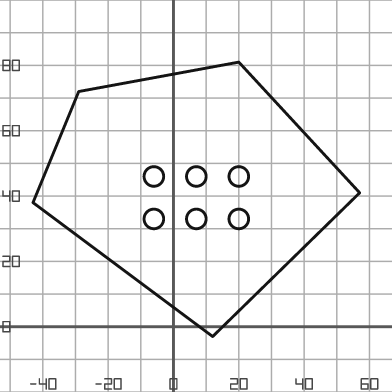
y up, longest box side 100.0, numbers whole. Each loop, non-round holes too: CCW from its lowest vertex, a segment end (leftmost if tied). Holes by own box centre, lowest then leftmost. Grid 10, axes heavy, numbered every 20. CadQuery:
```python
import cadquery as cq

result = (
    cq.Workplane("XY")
    .moveTo(12.0, -3.0)
    .lineTo(57.0, 41.0)
    .lineTo(20.0, 81.0)
    .lineTo(-29.0, 72.0)
    .lineTo(-43.0, 38.0)
    .close()
    .moveTo(-6.0, 33.0)
    .circle(3.0)
    .moveTo(7.0, 33.0)
    .circle(3.0)
    .moveTo(20.0, 33.0)
    .circle(3.0)
    .moveTo(-6.0, 46.0)
    .circle(3.0)
    .moveTo(7.0, 46.0)
    .circle(3.0)
    .moveTo(20.0, 46.0)
    .circle(3.0)
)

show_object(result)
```